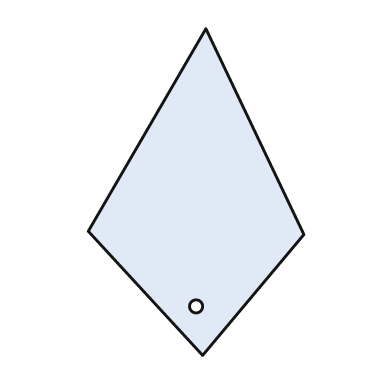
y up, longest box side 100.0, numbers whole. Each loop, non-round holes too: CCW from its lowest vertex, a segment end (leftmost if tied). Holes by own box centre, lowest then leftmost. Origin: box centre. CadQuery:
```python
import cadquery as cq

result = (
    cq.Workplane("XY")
    .moveTo(2.0, -50.0)
    .lineTo(33.0, -13.0)
    .lineTo(3.0, 50.0)
    .lineTo(-33.0, -12.0)
    .close()
    .moveTo(0.0, -35.0)
    .circle(2.0)
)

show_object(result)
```